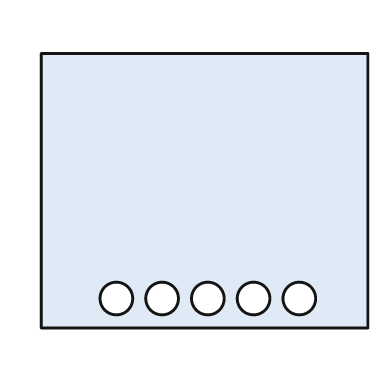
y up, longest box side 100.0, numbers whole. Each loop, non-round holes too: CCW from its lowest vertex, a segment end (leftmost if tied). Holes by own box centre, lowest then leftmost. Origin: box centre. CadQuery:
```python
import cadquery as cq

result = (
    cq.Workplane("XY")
    .moveTo(-50.0, -42.0)
    .lineTo(50.0, -42.0)
    .lineTo(50.0, 42.0)
    .lineTo(-50.0, 42.0)
    .close()
    .moveTo(-27.0, -33.0)
    .circle(5.0)
    .moveTo(-13.0, -33.0)
    .circle(5.0)
    .moveTo(1.0, -33.0)
    .circle(5.0)
    .moveTo(15.0, -33.0)
    .circle(5.0)
    .moveTo(29.0, -33.0)
    .circle(5.0)
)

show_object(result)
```